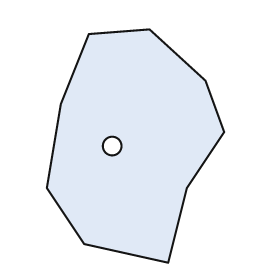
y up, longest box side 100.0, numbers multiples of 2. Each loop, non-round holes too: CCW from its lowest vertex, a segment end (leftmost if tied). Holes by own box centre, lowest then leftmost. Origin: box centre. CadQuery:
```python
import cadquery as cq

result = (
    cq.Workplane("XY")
    .moveTo(14.0, -50.0)
    .lineTo(22.0, -18.0)
    .lineTo(38.0, 6.0)
    .lineTo(30.0, 28.0)
    .lineTo(6.0, 50.0)
    .lineTo(-20.0, 48.0)
    .lineTo(-32.0, 18.0)
    .lineTo(-38.0, -18.0)
    .lineTo(-22.0, -42.0)
    .close()
    .moveTo(-10.0, 0.0)
    .circle(4.0)
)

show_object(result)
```